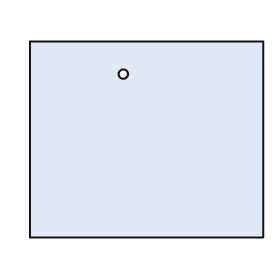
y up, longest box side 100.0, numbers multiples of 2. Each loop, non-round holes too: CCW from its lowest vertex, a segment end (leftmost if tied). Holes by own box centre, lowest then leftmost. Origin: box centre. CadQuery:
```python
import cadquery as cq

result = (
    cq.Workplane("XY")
    .moveTo(-50.0, -42.0)
    .lineTo(50.0, -42.0)
    .lineTo(50.0, 42.0)
    .lineTo(-50.0, 42.0)
    .close()
    .moveTo(-10.0, 28.0)
    .circle(2.0)
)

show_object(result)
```